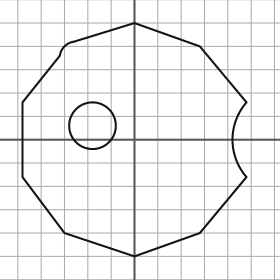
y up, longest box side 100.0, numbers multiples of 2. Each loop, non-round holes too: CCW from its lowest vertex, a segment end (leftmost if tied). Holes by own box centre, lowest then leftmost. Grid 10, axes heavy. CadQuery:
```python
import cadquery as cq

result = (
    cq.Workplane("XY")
    .moveTo(0.0, -50.0)
    .lineTo(28.0, -40.0)
    .lineTo(48.0, -16.0)
    .threePointArc((42.0, 0.0), (48.0, 16.0))
    .lineTo(28.0, 40.0)
    .lineTo(0.0, 50.0)
    .lineTo(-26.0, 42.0)
    .threePointArc((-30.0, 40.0), (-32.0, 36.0))
    .lineTo(-48.0, 16.0)
    .lineTo(-48.0, -16.0)
    .lineTo(-30.0, -40.0)
    .close()
    .moveTo(-18.0, 6.0)
    .circle(10.0)
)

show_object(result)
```